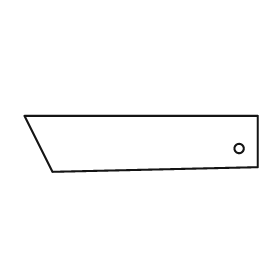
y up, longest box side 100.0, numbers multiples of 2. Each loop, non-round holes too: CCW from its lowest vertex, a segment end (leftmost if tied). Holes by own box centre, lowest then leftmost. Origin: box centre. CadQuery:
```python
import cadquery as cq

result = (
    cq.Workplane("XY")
    .moveTo(-38.0, -12.0)
    .lineTo(50.0, -10.0)
    .lineTo(50.0, 12.0)
    .lineTo(-50.0, 12.0)
    .close()
    .moveTo(42.0, -2.0)
    .circle(2.0)
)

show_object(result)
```